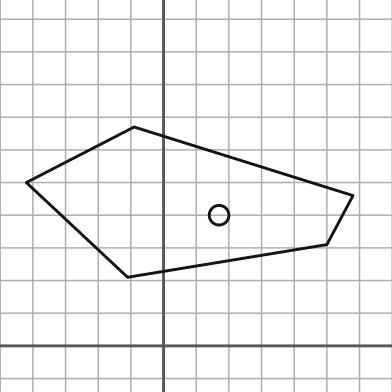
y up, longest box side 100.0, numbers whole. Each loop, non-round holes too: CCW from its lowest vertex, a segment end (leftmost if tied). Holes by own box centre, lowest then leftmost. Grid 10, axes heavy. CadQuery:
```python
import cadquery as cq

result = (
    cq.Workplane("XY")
    .moveTo(-11.0, 21.0)
    .lineTo(50.0, 31.0)
    .lineTo(58.0, 46.0)
    .lineTo(-9.0, 67.0)
    .lineTo(-42.0, 50.0)
    .close()
    .moveTo(17.0, 40.0)
    .circle(3.0)
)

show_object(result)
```